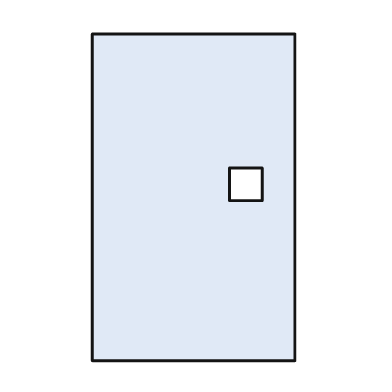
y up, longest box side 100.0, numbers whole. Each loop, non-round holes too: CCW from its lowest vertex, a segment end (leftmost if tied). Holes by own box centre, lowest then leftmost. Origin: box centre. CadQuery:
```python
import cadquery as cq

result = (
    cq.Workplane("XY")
    .moveTo(-31.0, -50.0)
    .lineTo(31.0, -50.0)
    .lineTo(31.0, 50.0)
    .lineTo(-31.0, 50.0)
    .close()
    .moveTo(11.0, -1.0)
    .lineTo(21.0, -1.0)
    .lineTo(21.0, 9.0)
    .lineTo(11.0, 9.0)
    .close()
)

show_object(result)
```